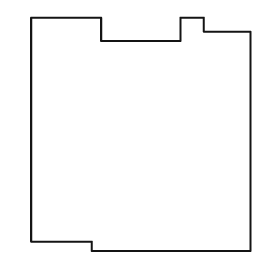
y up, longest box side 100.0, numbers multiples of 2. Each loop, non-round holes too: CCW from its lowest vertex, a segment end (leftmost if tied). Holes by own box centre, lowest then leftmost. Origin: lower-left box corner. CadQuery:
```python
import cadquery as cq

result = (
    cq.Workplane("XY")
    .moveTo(26.0, 0.0)
    .lineTo(94.0, 0.0)
    .lineTo(94.0, 94.0)
    .lineTo(74.0, 94.0)
    .lineTo(74.0, 100.0)
    .lineTo(64.0, 100.0)
    .lineTo(64.0, 90.0)
    .lineTo(30.0, 90.0)
    .lineTo(30.0, 100.0)
    .lineTo(0.0, 100.0)
    .lineTo(0.0, 4.0)
    .lineTo(26.0, 4.0)
    .close()
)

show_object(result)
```